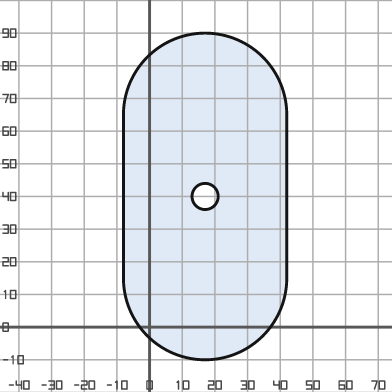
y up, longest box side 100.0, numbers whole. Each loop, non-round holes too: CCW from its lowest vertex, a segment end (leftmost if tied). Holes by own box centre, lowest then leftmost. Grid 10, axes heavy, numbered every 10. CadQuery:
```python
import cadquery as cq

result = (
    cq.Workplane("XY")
    .moveTo(-8.0, 15.0)
    .threePointArc((17.0, -10.0), (42.0, 15.0))
    .lineTo(42.0, 65.0)
    .threePointArc((17.0, 90.0), (-8.0, 65.0))
    .close()
    .moveTo(17.0, 40.0)
    .circle(4.0)
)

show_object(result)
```